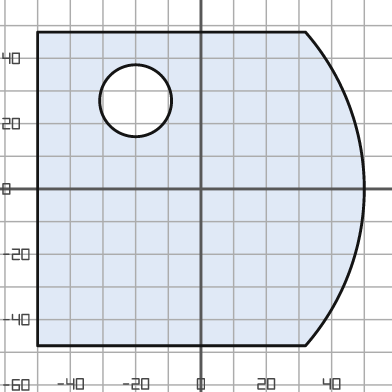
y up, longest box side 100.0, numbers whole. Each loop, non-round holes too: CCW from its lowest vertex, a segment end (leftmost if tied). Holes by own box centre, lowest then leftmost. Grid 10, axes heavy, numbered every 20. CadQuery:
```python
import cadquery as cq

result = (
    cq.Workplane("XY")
    .moveTo(-50.0, -48.0)
    .lineTo(32.0, -48.0)
    .threePointArc((50.0, 0.0), (32.0, 48.0))
    .lineTo(-50.0, 48.0)
    .close()
    .moveTo(-20.0, 27.0)
    .circle(11.0)
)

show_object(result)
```